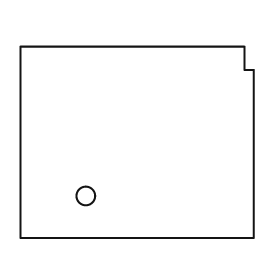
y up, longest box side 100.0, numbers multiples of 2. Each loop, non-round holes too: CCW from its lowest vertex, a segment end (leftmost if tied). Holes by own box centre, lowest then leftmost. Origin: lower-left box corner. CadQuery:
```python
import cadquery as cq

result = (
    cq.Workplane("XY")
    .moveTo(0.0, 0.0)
    .lineTo(100.0, 0.0)
    .lineTo(100.0, 72.0)
    .lineTo(96.0, 72.0)
    .lineTo(96.0, 82.0)
    .lineTo(0.0, 82.0)
    .close()
    .moveTo(28.0, 18.0)
    .circle(4.0)
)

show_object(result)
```